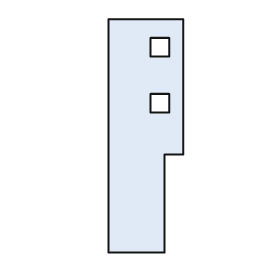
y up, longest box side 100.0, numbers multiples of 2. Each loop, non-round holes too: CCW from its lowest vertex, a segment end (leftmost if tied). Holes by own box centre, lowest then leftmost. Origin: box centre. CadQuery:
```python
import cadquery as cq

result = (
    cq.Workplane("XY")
    .moveTo(-16.0, -50.0)
    .lineTo(8.0, -50.0)
    .lineTo(8.0, -8.0)
    .lineTo(16.0, -8.0)
    .lineTo(16.0, 50.0)
    .lineTo(-16.0, 50.0)
    .close()
    .moveTo(2.0, 10.0)
    .lineTo(10.0, 10.0)
    .lineTo(10.0, 18.0)
    .lineTo(2.0, 18.0)
    .close()
    .moveTo(2.0, 34.0)
    .lineTo(10.0, 34.0)
    .lineTo(10.0, 42.0)
    .lineTo(2.0, 42.0)
    .close()
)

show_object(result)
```